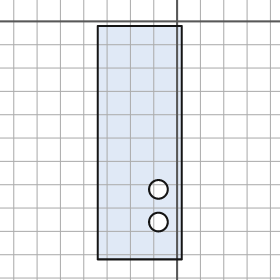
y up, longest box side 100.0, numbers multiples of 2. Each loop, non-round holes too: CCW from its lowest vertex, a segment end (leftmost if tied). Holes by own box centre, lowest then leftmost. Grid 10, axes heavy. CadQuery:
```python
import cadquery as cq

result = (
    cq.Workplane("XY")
    .moveTo(-34.0, -102.0)
    .lineTo(2.0, -102.0)
    .lineTo(2.0, -2.0)
    .lineTo(-34.0, -2.0)
    .close()
    .moveTo(-8.0, -86.0)
    .circle(4.0)
    .moveTo(-8.0, -72.0)
    .circle(4.0)
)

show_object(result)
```